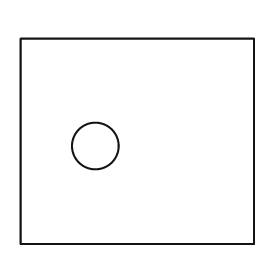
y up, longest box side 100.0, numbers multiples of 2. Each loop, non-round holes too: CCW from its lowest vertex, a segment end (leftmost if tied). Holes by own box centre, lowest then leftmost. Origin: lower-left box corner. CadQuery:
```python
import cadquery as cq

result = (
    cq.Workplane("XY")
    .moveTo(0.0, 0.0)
    .lineTo(100.0, 0.0)
    .lineTo(100.0, 88.0)
    .lineTo(0.0, 88.0)
    .close()
    .moveTo(32.0, 42.0)
    .circle(10.0)
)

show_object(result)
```